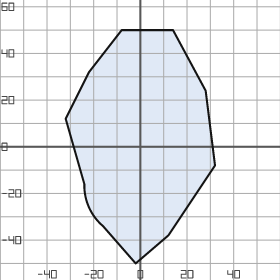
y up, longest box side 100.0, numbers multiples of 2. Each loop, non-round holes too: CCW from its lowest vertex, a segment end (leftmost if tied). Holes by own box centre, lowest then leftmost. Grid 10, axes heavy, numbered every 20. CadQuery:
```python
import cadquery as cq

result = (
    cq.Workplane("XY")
    .moveTo(-2.0, -50.0)
    .lineTo(12.0, -38.0)
    .lineTo(32.0, -8.0)
    .lineTo(28.0, 24.0)
    .lineTo(14.0, 50.0)
    .lineTo(-8.0, 50.0)
    .lineTo(-22.0, 32.0)
    .lineTo(-32.0, 12.0)
    .lineTo(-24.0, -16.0)
    .threePointArc((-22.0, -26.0), (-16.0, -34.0))
    .close()
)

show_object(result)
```